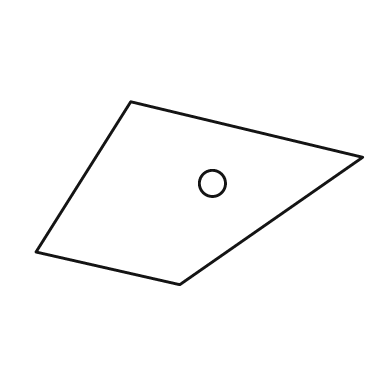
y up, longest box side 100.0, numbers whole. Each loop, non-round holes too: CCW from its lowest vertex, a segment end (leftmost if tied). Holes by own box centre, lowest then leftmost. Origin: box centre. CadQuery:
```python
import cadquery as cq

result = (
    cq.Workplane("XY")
    .moveTo(-6.0, -28.0)
    .lineTo(50.0, 11.0)
    .lineTo(-21.0, 28.0)
    .lineTo(-50.0, -18.0)
    .close()
    .moveTo(4.0, 3.0)
    .circle(4.0)
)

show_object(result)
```